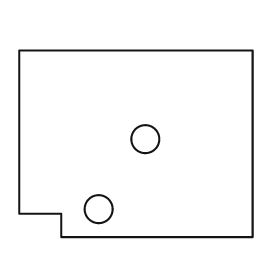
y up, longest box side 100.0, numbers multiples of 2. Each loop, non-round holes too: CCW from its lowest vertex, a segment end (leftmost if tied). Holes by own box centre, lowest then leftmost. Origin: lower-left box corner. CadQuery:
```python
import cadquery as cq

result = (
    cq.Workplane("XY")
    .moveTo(18.0, 0.0)
    .lineTo(100.0, 0.0)
    .lineTo(100.0, 80.0)
    .lineTo(0.0, 80.0)
    .lineTo(0.0, 10.0)
    .lineTo(18.0, 10.0)
    .close()
    .moveTo(34.0, 12.0)
    .circle(6.0)
    .moveTo(54.0, 42.0)
    .circle(6.0)
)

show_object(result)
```